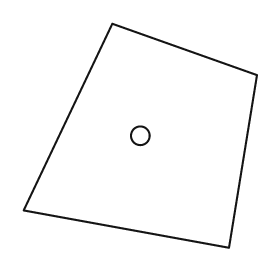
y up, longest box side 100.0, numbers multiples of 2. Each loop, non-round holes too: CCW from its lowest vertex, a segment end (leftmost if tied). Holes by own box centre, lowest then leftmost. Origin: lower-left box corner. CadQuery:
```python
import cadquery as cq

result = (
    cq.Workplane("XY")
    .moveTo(88.0, 0.0)
    .lineTo(100.0, 74.0)
    .lineTo(38.0, 96.0)
    .lineTo(0.0, 16.0)
    .close()
    .moveTo(50.0, 48.0)
    .circle(4.0)
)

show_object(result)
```